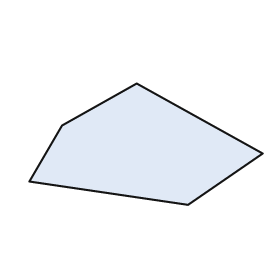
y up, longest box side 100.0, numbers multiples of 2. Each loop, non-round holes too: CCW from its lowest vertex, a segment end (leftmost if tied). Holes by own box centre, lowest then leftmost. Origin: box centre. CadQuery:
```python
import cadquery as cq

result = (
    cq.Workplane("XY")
    .moveTo(18.0, -26.0)
    .lineTo(50.0, -4.0)
    .lineTo(-4.0, 26.0)
    .lineTo(-36.0, 8.0)
    .lineTo(-50.0, -16.0)
    .close()
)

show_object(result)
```